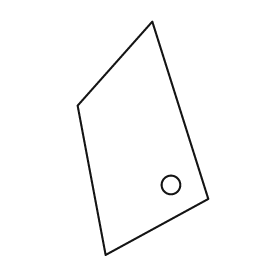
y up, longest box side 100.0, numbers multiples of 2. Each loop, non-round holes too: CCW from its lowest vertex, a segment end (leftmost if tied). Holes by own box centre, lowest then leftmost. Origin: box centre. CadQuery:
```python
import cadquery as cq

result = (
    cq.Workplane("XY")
    .moveTo(-16.0, -50.0)
    .lineTo(28.0, -26.0)
    .lineTo(4.0, 50.0)
    .lineTo(-28.0, 14.0)
    .close()
    .moveTo(12.0, -20.0)
    .circle(4.0)
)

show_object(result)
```